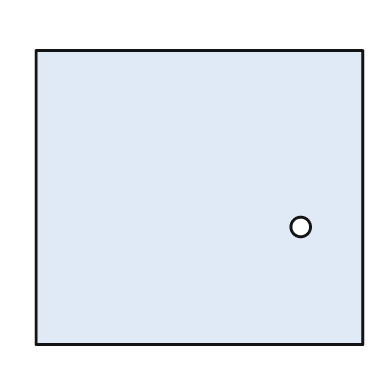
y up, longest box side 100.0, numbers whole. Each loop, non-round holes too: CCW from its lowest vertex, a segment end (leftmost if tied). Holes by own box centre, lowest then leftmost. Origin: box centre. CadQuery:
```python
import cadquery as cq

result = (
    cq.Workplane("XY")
    .moveTo(-50.0, -45.0)
    .lineTo(50.0, -45.0)
    .lineTo(50.0, 45.0)
    .lineTo(-50.0, 45.0)
    .close()
    .moveTo(31.0, -9.0)
    .circle(3.0)
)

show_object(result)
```